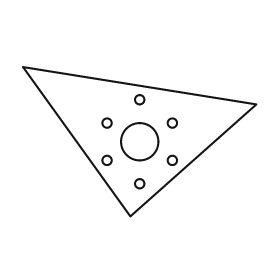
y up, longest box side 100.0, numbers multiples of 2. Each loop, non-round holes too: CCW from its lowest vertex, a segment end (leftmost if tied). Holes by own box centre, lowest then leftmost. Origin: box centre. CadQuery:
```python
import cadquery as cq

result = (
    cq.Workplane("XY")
    .moveTo(-4.0, -32.0)
    .lineTo(50.0, 16.0)
    .lineTo(-50.0, 32.0)
    .close()
    .moveTo(0.0, -18.0)
    .circle(2.0)
    .moveTo(-14.0, -8.0)
    .circle(2.0)
    .moveTo(14.0, -8.0)
    .circle(2.0)
    .moveTo(0.0, 0.0)
    .circle(8.0)
    .moveTo(-14.0, 8.0)
    .circle(2.0)
    .moveTo(14.0, 8.0)
    .circle(2.0)
    .moveTo(0.0, 18.0)
    .circle(2.0)
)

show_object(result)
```